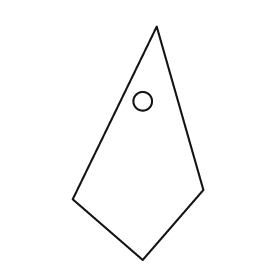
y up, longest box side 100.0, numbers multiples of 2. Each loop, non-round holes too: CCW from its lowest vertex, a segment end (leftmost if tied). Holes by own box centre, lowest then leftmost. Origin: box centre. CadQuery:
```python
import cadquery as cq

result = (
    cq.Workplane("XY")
    .moveTo(2.0, -50.0)
    .lineTo(28.0, -20.0)
    .lineTo(8.0, 50.0)
    .lineTo(-28.0, -24.0)
    .close()
    .moveTo(2.0, 18.0)
    .circle(4.0)
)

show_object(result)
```